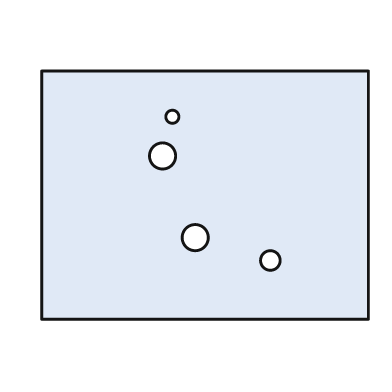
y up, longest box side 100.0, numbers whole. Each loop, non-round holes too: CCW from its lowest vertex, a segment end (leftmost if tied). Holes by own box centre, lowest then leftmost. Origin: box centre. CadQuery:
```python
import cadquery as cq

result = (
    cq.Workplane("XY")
    .moveTo(-50.0, -38.0)
    .lineTo(50.0, -38.0)
    .lineTo(50.0, 38.0)
    .lineTo(-50.0, 38.0)
    .close()
    .moveTo(20.0, -20.0)
    .circle(3.0)
    .moveTo(-3.0, -13.0)
    .circle(4.0)
    .moveTo(-13.0, 12.0)
    .circle(4.0)
    .moveTo(-10.0, 24.0)
    .circle(2.0)
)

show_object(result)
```